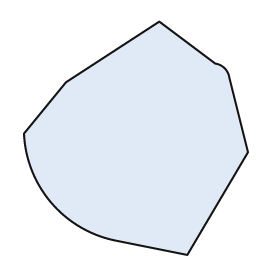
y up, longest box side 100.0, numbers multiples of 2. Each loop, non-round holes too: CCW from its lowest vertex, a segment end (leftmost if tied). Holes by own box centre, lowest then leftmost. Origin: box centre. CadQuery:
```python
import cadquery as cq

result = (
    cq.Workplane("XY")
    .moveTo(22.0, -50.0)
    .lineTo(48.0, -6.0)
    .lineTo(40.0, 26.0)
    .threePointArc((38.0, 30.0), (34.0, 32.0))
    .lineTo(10.0, 50.0)
    .lineTo(-30.0, 24.0)
    .lineTo(-48.0, 2.0)
    .threePointArc((-36.0, -28.0), (-8.0, -44.0))
    .close()
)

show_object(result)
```